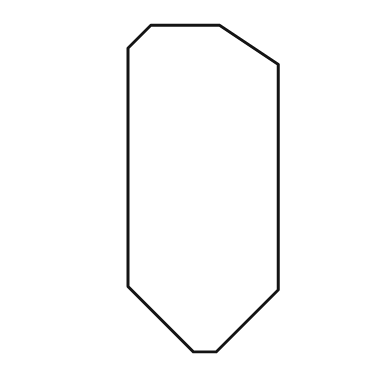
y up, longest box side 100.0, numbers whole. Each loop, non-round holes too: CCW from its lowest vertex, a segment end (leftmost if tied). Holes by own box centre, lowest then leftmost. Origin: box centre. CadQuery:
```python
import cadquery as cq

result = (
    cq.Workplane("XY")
    .moveTo(-3.0, -50.0)
    .lineTo(4.0, -50.0)
    .lineTo(23.0, -31.0)
    .lineTo(23.0, 38.0)
    .lineTo(5.0, 50.0)
    .lineTo(-16.0, 50.0)
    .lineTo(-23.0, 43.0)
    .lineTo(-23.0, -30.0)
    .close()
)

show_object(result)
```